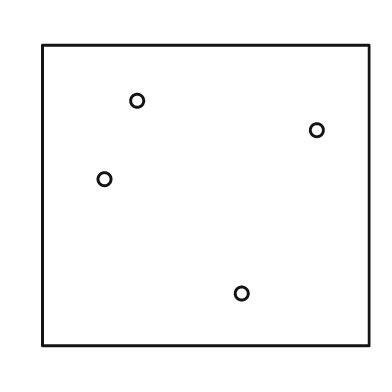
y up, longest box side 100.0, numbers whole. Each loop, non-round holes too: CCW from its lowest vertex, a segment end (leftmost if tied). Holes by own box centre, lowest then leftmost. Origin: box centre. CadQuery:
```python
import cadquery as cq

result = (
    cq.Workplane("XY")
    .moveTo(-50.0, -46.0)
    .lineTo(50.0, -46.0)
    .lineTo(50.0, 46.0)
    .lineTo(-50.0, 46.0)
    .close()
    .moveTo(11.0, -30.0)
    .circle(2.0)
    .moveTo(-31.0, 5.0)
    .circle(2.0)
    .moveTo(34.0, 20.0)
    .circle(2.0)
    .moveTo(-21.0, 29.0)
    .circle(2.0)
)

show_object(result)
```